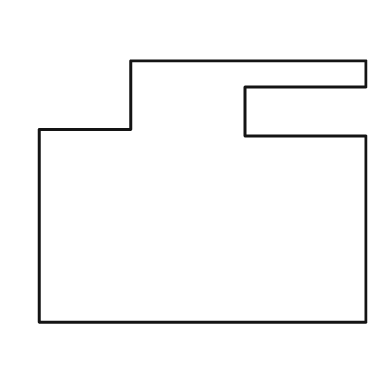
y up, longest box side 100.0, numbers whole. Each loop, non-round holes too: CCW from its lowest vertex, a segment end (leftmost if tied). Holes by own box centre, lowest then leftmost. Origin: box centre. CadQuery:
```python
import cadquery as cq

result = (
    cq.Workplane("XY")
    .moveTo(-50.0, -40.0)
    .lineTo(50.0, -40.0)
    .lineTo(50.0, 17.0)
    .lineTo(13.0, 17.0)
    .lineTo(13.0, 32.0)
    .lineTo(50.0, 32.0)
    .lineTo(50.0, 40.0)
    .lineTo(-22.0, 40.0)
    .lineTo(-22.0, 19.0)
    .lineTo(-50.0, 19.0)
    .close()
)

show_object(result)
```